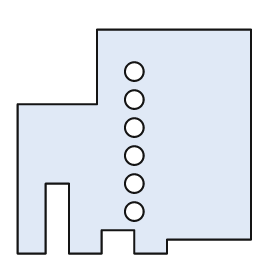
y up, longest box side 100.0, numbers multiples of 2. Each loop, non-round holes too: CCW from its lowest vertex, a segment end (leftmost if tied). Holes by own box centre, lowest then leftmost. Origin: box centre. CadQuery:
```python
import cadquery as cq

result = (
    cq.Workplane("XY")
    .moveTo(-50.0, -48.0)
    .lineTo(-38.0, -48.0)
    .lineTo(-38.0, -18.0)
    .lineTo(-28.0, -18.0)
    .lineTo(-28.0, -48.0)
    .lineTo(-14.0, -48.0)
    .lineTo(-14.0, -38.0)
    .lineTo(0.0, -38.0)
    .lineTo(0.0, -48.0)
    .lineTo(14.0, -48.0)
    .lineTo(14.0, -42.0)
    .lineTo(50.0, -42.0)
    .lineTo(50.0, 48.0)
    .lineTo(-16.0, 48.0)
    .lineTo(-16.0, 16.0)
    .lineTo(-50.0, 16.0)
    .close()
    .moveTo(0.0, -30.0)
    .circle(4.0)
    .moveTo(0.0, -18.0)
    .circle(4.0)
    .moveTo(0.0, -6.0)
    .circle(4.0)
    .moveTo(0.0, 6.0)
    .circle(4.0)
    .moveTo(0.0, 18.0)
    .circle(4.0)
    .moveTo(0.0, 30.0)
    .circle(4.0)
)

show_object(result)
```